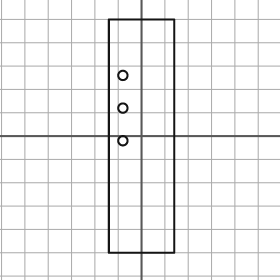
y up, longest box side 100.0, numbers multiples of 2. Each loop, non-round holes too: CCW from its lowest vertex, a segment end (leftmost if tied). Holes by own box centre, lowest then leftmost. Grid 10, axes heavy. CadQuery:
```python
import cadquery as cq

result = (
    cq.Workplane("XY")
    .moveTo(-14.0, -50.0)
    .lineTo(14.0, -50.0)
    .lineTo(14.0, 50.0)
    .lineTo(-14.0, 50.0)
    .close()
    .moveTo(-8.0, -2.0)
    .circle(2.0)
    .moveTo(-8.0, 12.0)
    .circle(2.0)
    .moveTo(-8.0, 26.0)
    .circle(2.0)
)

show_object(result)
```